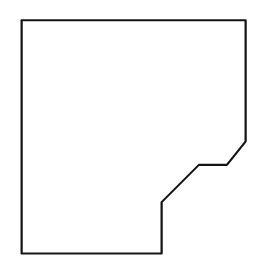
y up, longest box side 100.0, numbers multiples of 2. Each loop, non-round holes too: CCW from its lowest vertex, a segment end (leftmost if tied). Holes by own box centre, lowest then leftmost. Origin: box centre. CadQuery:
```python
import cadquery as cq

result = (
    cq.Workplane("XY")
    .moveTo(-48.0, -50.0)
    .lineTo(12.0, -50.0)
    .lineTo(12.0, -28.0)
    .lineTo(28.0, -12.0)
    .lineTo(40.0, -12.0)
    .lineTo(48.0, -2.0)
    .lineTo(48.0, 50.0)
    .lineTo(-48.0, 50.0)
    .close()
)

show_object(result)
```